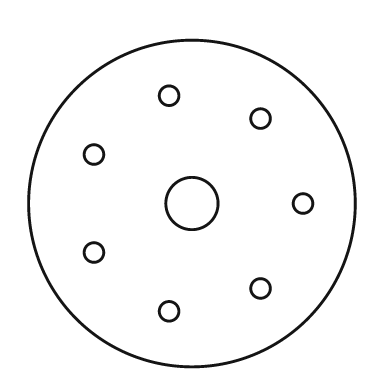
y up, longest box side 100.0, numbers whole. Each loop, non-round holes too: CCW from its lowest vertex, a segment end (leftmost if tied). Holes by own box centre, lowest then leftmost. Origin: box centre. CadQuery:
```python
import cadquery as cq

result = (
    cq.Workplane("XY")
    .moveTo(0.0, 0.0)
    .circle(50.0)
    .moveTo(-7.0, -33.0)
    .circle(3.0)
    .moveTo(21.0, -26.0)
    .circle(3.0)
    .moveTo(-30.0, -15.0)
    .circle(3.0)
    .moveTo(0.0, 0.0)
    .circle(8.0)
    .moveTo(34.0, 0.0)
    .circle(3.0)
    .moveTo(-30.0, 15.0)
    .circle(3.0)
    .moveTo(21.0, 26.0)
    .circle(3.0)
    .moveTo(-7.0, 33.0)
    .circle(3.0)
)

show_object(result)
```